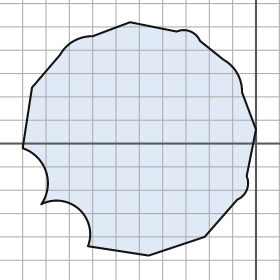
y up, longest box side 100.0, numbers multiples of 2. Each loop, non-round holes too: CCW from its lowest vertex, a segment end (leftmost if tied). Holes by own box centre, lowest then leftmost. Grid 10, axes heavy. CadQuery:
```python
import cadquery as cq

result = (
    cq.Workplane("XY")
    .moveTo(-46.0, -48.0)
    .lineTo(-22.0, -40.0)
    .lineTo(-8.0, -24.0)
    .threePointArc((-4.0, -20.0), (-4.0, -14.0))
    .lineTo(0.0, 6.0)
    .lineTo(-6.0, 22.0)
    .threePointArc((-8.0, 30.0), (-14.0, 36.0))
    .lineTo(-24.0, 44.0)
    .threePointArc((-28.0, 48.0), (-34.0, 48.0))
    .lineTo(-54.0, 52.0)
    .lineTo(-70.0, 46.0)
    .threePointArc((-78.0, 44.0), (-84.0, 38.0))
    .lineTo(-96.0, 24.0)
    .lineTo(-100.0, -2.0)
    .threePointArc((-90.0, -12.0), (-92.0, -26.0))
    .threePointArc((-76.0, -28.0), (-72.0, -44.0))
    .close()
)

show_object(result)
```